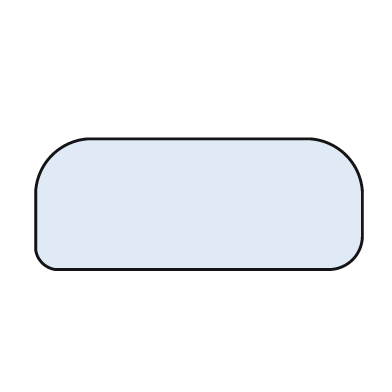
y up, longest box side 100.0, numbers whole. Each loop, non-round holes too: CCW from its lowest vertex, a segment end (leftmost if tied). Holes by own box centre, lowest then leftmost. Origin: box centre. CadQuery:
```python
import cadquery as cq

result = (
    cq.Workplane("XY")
    .moveTo(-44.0, -20.0)
    .lineTo(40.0, -20.0)
    .threePointArc((47.0, -17.0), (50.0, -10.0))
    .lineTo(50.0, 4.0)
    .threePointArc((45.0, 15.0), (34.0, 20.0))
    .lineTo(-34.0, 20.0)
    .threePointArc((-45.0, 15.0), (-50.0, 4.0))
    .lineTo(-50.0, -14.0)
    .threePointArc((-48.0, -18.0), (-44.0, -20.0))
    .close()
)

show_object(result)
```